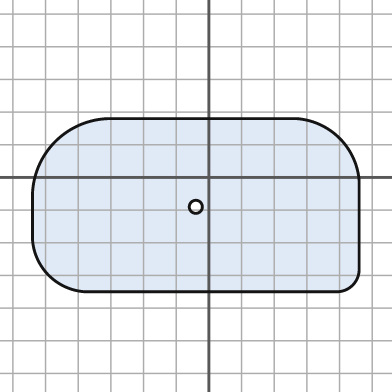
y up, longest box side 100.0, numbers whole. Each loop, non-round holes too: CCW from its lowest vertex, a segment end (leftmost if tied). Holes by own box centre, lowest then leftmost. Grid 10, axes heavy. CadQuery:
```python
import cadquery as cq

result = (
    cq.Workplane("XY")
    .moveTo(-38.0, -35.0)
    .lineTo(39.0, -35.0)
    .threePointArc((44.0, -33.0), (46.0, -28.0))
    .lineTo(46.0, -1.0)
    .threePointArc((40.0, 12.0), (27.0, 18.0))
    .lineTo(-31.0, 18.0)
    .threePointArc((-47.0, 11.0), (-54.0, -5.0))
    .lineTo(-54.0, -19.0)
    .threePointArc((-49.0, -30.0), (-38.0, -35.0))
    .close()
    .moveTo(-4.0, -9.0)
    .circle(2.0)
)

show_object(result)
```